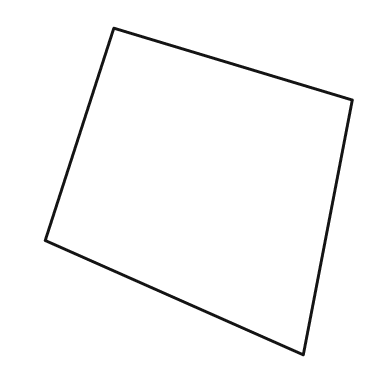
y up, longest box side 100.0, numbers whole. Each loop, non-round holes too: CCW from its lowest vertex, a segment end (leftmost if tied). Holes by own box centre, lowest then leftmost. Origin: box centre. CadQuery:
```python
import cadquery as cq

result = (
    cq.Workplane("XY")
    .moveTo(32.0, -50.0)
    .lineTo(47.0, 28.0)
    .lineTo(-26.0, 50.0)
    .lineTo(-47.0, -15.0)
    .close()
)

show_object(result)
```